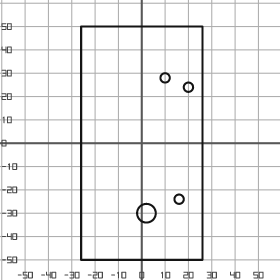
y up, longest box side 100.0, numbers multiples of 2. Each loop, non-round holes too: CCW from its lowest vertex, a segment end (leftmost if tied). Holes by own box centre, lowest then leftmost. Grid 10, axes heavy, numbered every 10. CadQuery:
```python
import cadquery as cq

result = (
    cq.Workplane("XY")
    .moveTo(-26.0, -50.0)
    .lineTo(26.0, -50.0)
    .lineTo(26.0, 50.0)
    .lineTo(-26.0, 50.0)
    .close()
    .moveTo(2.0, -30.0)
    .circle(4.0)
    .moveTo(16.0, -24.0)
    .circle(2.0)
    .moveTo(20.0, 24.0)
    .circle(2.0)
    .moveTo(10.0, 28.0)
    .circle(2.0)
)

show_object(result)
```